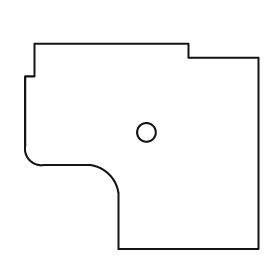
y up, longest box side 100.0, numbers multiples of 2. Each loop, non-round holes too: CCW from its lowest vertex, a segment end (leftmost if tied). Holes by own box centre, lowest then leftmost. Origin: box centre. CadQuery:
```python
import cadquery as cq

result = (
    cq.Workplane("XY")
    .moveTo(-10.0, -44.0)
    .lineTo(50.0, -44.0)
    .lineTo(50.0, 38.0)
    .lineTo(20.0, 38.0)
    .lineTo(20.0, 44.0)
    .lineTo(-46.0, 44.0)
    .lineTo(-46.0, 30.0)
    .lineTo(-50.0, 30.0)
    .lineTo(-50.0, 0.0)
    .threePointArc((-48.0, -6.0), (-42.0, -8.0))
    .lineTo(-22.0, -8.0)
    .threePointArc((-14.0, -12.0), (-10.0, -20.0))
    .close()
    .moveTo(2.0, 6.0)
    .circle(4.0)
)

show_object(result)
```